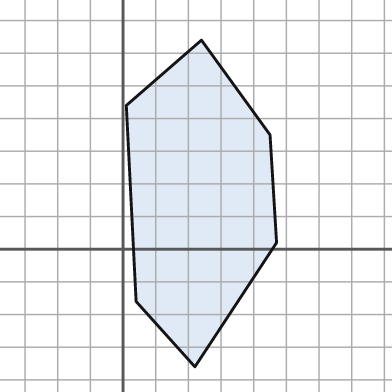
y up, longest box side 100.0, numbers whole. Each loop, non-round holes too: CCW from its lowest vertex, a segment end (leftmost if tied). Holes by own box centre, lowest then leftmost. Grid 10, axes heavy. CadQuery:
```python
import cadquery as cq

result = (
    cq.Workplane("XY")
    .moveTo(22.0, -36.0)
    .lineTo(47.0, 2.0)
    .lineTo(45.0, 35.0)
    .lineTo(24.0, 64.0)
    .lineTo(1.0, 44.0)
    .lineTo(4.0, -16.0)
    .close()
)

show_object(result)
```